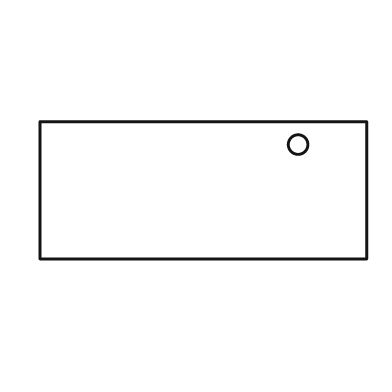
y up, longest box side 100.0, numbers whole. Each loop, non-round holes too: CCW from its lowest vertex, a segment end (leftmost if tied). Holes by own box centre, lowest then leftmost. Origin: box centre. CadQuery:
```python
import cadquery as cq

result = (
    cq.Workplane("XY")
    .moveTo(-50.0, -21.0)
    .lineTo(50.0, -21.0)
    .lineTo(50.0, 21.0)
    .lineTo(-50.0, 21.0)
    .close()
    .moveTo(29.0, 14.0)
    .circle(3.0)
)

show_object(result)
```